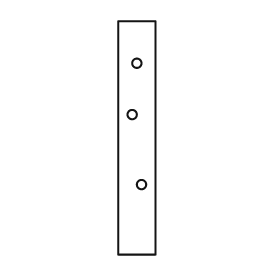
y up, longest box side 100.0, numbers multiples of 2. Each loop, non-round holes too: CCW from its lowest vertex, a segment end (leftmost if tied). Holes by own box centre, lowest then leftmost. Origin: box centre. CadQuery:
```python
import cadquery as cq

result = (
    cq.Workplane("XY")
    .moveTo(-8.0, -50.0)
    .lineTo(8.0, -50.0)
    .lineTo(8.0, 50.0)
    .lineTo(-8.0, 50.0)
    .close()
    .moveTo(2.0, -20.0)
    .circle(2.0)
    .moveTo(-2.0, 10.0)
    .circle(2.0)
    .moveTo(0.0, 32.0)
    .circle(2.0)
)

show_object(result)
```